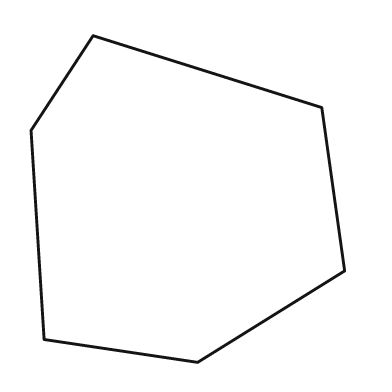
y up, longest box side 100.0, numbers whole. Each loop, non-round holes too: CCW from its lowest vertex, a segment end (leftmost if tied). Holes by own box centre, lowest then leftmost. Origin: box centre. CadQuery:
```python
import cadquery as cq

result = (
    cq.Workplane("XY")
    .moveTo(3.0, -50.0)
    .lineTo(48.0, -22.0)
    .lineTo(41.0, 28.0)
    .lineTo(-29.0, 50.0)
    .lineTo(-48.0, 21.0)
    .lineTo(-44.0, -43.0)
    .close()
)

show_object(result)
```